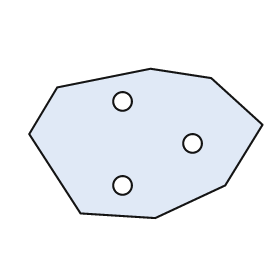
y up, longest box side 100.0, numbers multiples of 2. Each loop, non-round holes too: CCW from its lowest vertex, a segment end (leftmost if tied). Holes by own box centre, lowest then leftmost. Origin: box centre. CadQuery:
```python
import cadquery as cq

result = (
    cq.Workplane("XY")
    .moveTo(4.0, -32.0)
    .lineTo(34.0, -18.0)
    .lineTo(50.0, 8.0)
    .lineTo(28.0, 28.0)
    .lineTo(2.0, 32.0)
    .lineTo(-38.0, 24.0)
    .lineTo(-50.0, 4.0)
    .lineTo(-28.0, -30.0)
    .close()
    .moveTo(-10.0, -18.0)
    .circle(4.0)
    .moveTo(20.0, 0.0)
    .circle(4.0)
    .moveTo(-10.0, 18.0)
    .circle(4.0)
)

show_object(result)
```